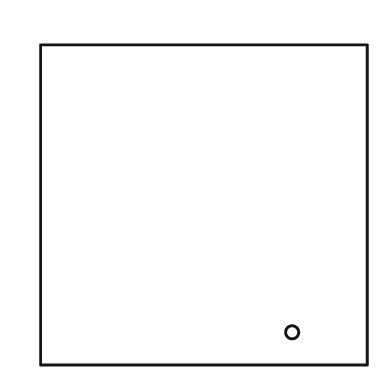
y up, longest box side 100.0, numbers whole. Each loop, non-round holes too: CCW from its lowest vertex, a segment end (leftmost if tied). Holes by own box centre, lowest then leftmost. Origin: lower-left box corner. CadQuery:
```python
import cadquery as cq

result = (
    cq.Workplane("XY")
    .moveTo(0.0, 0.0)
    .lineTo(100.0, 0.0)
    .lineTo(100.0, 98.0)
    .lineTo(0.0, 98.0)
    .close()
    .moveTo(77.0, 10.0)
    .circle(2.0)
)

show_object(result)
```